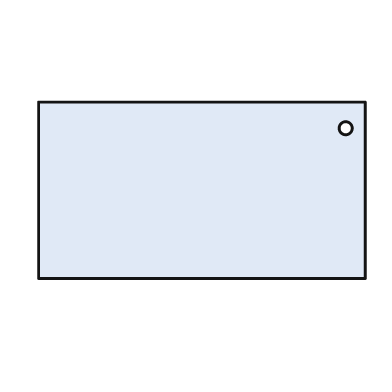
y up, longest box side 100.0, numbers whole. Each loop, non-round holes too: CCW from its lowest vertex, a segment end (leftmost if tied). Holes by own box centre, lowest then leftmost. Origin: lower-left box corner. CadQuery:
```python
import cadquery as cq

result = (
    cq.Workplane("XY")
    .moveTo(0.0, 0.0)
    .lineTo(100.0, 0.0)
    .lineTo(100.0, 54.0)
    .lineTo(0.0, 54.0)
    .close()
    .moveTo(94.0, 46.0)
    .circle(2.0)
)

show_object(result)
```